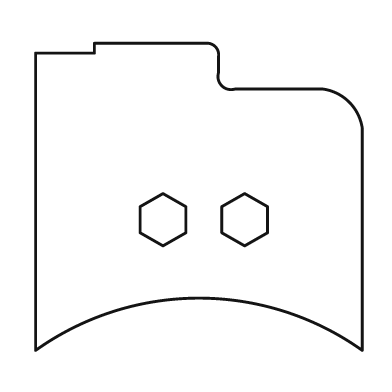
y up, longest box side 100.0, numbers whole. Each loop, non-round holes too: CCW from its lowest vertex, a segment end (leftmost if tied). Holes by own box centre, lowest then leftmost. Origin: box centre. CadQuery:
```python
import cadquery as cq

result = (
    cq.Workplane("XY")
    .moveTo(-50.0, -47.0)
    .threePointArc((0.0, -31.0), (50.0, -47.0))
    .lineTo(50.0, 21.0)
    .threePointArc((46.0, 29.0), (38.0, 33.0))
    .lineTo(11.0, 33.0)
    .threePointArc((7.0, 34.0), (6.0, 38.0))
    .lineTo(6.0, 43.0)
    .threePointArc((5.0, 46.0), (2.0, 47.0))
    .lineTo(-32.0, 47.0)
    .lineTo(-32.0, 44.0)
    .lineTo(-50.0, 44.0)
    .close()
    .moveTo(-11.0, -15.0)
    .lineTo(-4.0, -11.0)
    .lineTo(-4.0, -3.0)
    .lineTo(-11.0, 1.0)
    .lineTo(-18.0, -3.0)
    .lineTo(-18.0, -11.0)
    .close()
    .moveTo(14.0, -15.0)
    .lineTo(21.0, -11.0)
    .lineTo(21.0, -3.0)
    .lineTo(14.0, 1.0)
    .lineTo(7.0, -3.0)
    .lineTo(7.0, -11.0)
    .close()
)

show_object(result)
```